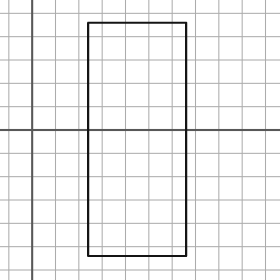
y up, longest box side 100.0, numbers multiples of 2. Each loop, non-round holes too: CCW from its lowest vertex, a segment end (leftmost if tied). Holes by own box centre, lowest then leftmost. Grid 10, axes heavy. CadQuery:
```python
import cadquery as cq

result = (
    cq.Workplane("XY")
    .moveTo(24.0, -54.0)
    .lineTo(66.0, -54.0)
    .lineTo(66.0, 46.0)
    .lineTo(24.0, 46.0)
    .close()
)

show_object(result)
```